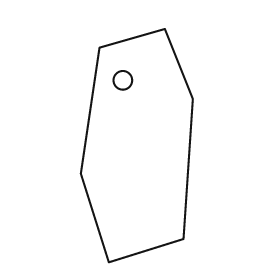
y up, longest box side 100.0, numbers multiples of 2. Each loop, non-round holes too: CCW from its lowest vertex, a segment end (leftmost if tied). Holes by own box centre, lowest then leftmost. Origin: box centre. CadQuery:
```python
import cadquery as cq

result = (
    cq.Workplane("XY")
    .moveTo(-12.0, -50.0)
    .lineTo(20.0, -40.0)
    .lineTo(24.0, 20.0)
    .lineTo(12.0, 50.0)
    .lineTo(-16.0, 42.0)
    .lineTo(-24.0, -12.0)
    .close()
    .moveTo(-6.0, 28.0)
    .circle(4.0)
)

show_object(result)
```